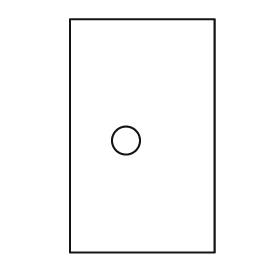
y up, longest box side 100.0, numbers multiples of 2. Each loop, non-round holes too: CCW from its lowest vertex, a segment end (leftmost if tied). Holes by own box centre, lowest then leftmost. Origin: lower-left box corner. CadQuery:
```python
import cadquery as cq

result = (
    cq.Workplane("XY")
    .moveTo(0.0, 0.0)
    .lineTo(62.0, 0.0)
    .lineTo(62.0, 100.0)
    .lineTo(0.0, 100.0)
    .close()
    .moveTo(24.0, 48.0)
    .circle(6.0)
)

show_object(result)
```